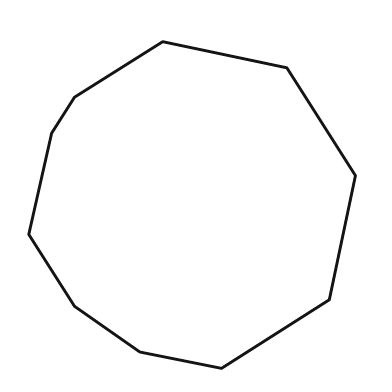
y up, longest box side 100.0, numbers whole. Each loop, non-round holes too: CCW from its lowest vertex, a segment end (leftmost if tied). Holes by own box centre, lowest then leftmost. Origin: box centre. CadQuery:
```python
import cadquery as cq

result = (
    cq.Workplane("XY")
    .moveTo(9.0, -50.0)
    .lineTo(42.0, -29.0)
    .lineTo(50.0, 9.0)
    .lineTo(29.0, 42.0)
    .lineTo(-9.0, 50.0)
    .lineTo(-36.0, 33.0)
    .lineTo(-43.0, 22.0)
    .lineTo(-50.0, -9.0)
    .lineTo(-36.0, -31.0)
    .lineTo(-16.0, -45.0)
    .close()
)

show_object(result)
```